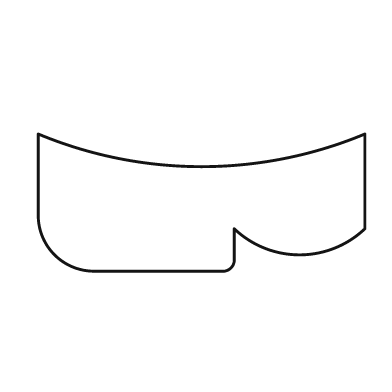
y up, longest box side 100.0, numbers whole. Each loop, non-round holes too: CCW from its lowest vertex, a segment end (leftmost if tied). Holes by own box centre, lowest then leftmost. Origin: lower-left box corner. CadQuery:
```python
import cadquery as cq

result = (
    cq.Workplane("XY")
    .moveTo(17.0, 0.0)
    .lineTo(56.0, 0.0)
    .threePointArc((59.0, 1.0), (60.0, 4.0))
    .lineTo(60.0, 13.0)
    .threePointArc((80.0, 5.0), (100.0, 13.0))
    .lineTo(100.0, 42.0)
    .threePointArc((50.0, 32.0), (0.0, 42.0))
    .lineTo(0.0, 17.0)
    .threePointArc((5.0, 5.0), (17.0, 0.0))
    .close()
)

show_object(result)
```